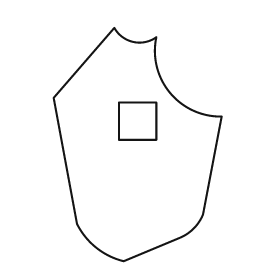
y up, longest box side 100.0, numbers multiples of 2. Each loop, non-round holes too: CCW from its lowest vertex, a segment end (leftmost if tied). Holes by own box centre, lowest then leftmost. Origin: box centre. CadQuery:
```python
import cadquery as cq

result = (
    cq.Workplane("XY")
    .moveTo(-6.0, -50.0)
    .lineTo(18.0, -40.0)
    .threePointArc((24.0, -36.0), (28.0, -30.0))
    .lineTo(36.0, 12.0)
    .threePointArc((14.0, 22.0), (8.0, 46.0))
    .threePointArc((-2.0, 44.0), (-10.0, 50.0))
    .lineTo(-36.0, 20.0)
    .lineTo(-26.0, -34.0)
    .threePointArc((-18.0, -44.0), (-6.0, -50.0))
    .close()
    .moveTo(-8.0, 2.0)
    .lineTo(8.0, 2.0)
    .lineTo(8.0, 18.0)
    .lineTo(-8.0, 18.0)
    .close()
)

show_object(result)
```